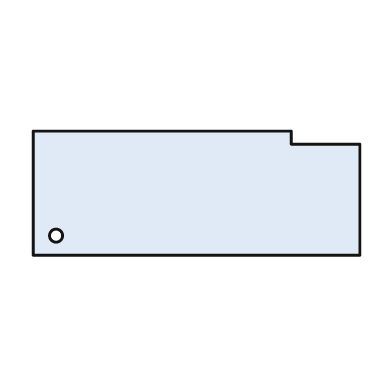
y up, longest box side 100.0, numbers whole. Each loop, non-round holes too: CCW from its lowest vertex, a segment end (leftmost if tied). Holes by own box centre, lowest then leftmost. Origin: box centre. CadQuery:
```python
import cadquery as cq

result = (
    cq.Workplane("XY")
    .moveTo(-50.0, -19.0)
    .lineTo(50.0, -19.0)
    .lineTo(50.0, 15.0)
    .lineTo(29.0, 15.0)
    .lineTo(29.0, 19.0)
    .lineTo(-50.0, 19.0)
    .close()
    .moveTo(-43.0, -13.0)
    .circle(2.0)
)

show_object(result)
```